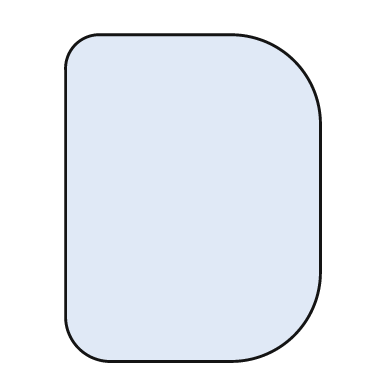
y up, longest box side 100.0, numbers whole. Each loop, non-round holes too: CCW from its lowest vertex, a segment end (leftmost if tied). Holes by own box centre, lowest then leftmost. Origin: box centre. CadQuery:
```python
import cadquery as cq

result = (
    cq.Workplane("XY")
    .moveTo(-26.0, -50.0)
    .lineTo(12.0, -50.0)
    .threePointArc((31.0, -42.0), (39.0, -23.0))
    .lineTo(39.0, 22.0)
    .threePointArc((31.0, 42.0), (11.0, 50.0))
    .lineTo(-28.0, 50.0)
    .threePointArc((-36.0, 47.0), (-39.0, 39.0))
    .lineTo(-39.0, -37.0)
    .threePointArc((-35.0, -46.0), (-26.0, -50.0))
    .close()
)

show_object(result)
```